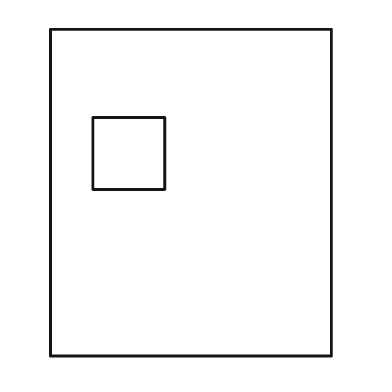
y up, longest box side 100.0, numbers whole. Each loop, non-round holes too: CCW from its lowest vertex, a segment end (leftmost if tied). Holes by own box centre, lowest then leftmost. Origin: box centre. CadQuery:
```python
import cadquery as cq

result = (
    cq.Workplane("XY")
    .moveTo(-43.0, -50.0)
    .lineTo(43.0, -50.0)
    .lineTo(43.0, 50.0)
    .lineTo(-43.0, 50.0)
    .close()
    .moveTo(-30.0, 1.0)
    .lineTo(-8.0, 1.0)
    .lineTo(-8.0, 23.0)
    .lineTo(-30.0, 23.0)
    .close()
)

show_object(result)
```